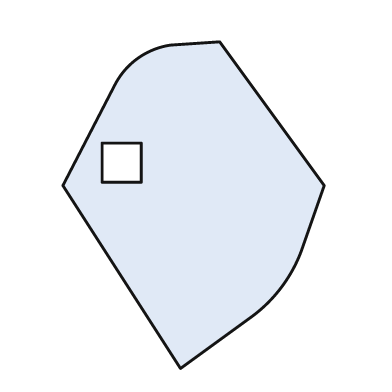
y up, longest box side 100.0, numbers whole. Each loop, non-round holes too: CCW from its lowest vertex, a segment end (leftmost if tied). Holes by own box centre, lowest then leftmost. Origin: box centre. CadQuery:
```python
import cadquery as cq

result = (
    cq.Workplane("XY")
    .moveTo(-4.0, -50.0)
    .lineTo(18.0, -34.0)
    .threePointArc((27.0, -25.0), (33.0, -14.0))
    .lineTo(40.0, 6.0)
    .lineTo(8.0, 50.0)
    .lineTo(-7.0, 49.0)
    .threePointArc((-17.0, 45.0), (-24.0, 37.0))
    .lineTo(-40.0, 6.0)
    .close()
    .moveTo(-28.0, 7.0)
    .lineTo(-16.0, 7.0)
    .lineTo(-16.0, 19.0)
    .lineTo(-28.0, 19.0)
    .close()
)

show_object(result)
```